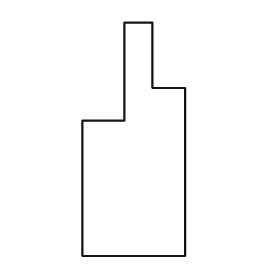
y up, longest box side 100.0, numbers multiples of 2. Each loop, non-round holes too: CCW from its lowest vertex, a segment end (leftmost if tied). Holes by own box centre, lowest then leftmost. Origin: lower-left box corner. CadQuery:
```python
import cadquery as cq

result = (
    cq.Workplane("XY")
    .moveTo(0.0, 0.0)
    .lineTo(44.0, 0.0)
    .lineTo(44.0, 72.0)
    .lineTo(30.0, 72.0)
    .lineTo(30.0, 100.0)
    .lineTo(18.0, 100.0)
    .lineTo(18.0, 58.0)
    .lineTo(0.0, 58.0)
    .close()
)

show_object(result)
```